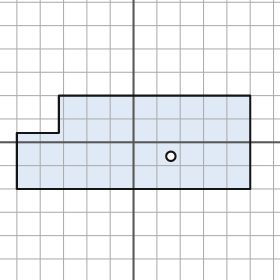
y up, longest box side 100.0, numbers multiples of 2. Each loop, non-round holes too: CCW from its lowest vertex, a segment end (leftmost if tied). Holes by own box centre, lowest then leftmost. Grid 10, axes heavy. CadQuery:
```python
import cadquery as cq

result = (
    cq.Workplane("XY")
    .moveTo(-50.0, -20.0)
    .lineTo(50.0, -20.0)
    .lineTo(50.0, 20.0)
    .lineTo(-32.0, 20.0)
    .lineTo(-32.0, 4.0)
    .lineTo(-50.0, 4.0)
    .close()
    .moveTo(16.0, -6.0)
    .circle(2.0)
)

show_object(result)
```